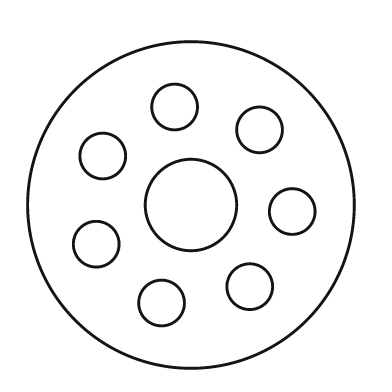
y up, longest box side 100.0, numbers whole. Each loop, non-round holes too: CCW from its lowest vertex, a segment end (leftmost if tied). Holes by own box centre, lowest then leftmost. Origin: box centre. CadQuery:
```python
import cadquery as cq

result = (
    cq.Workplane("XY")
    .moveTo(0.0, 0.0)
    .circle(50.0)
    .moveTo(-9.0, -30.0)
    .circle(7.0)
    .moveTo(18.0, -25.0)
    .circle(7.0)
    .moveTo(-29.0, -12.0)
    .circle(7.0)
    .moveTo(31.0, -2.0)
    .circle(7.0)
    .moveTo(0.0, 0.0)
    .circle(14.0)
    .moveTo(-27.0, 15.0)
    .circle(7.0)
    .moveTo(21.0, 23.0)
    .circle(7.0)
    .moveTo(-5.0, 30.0)
    .circle(7.0)
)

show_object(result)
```